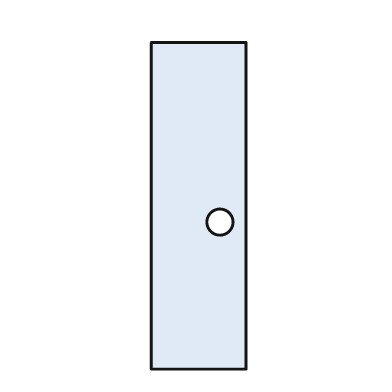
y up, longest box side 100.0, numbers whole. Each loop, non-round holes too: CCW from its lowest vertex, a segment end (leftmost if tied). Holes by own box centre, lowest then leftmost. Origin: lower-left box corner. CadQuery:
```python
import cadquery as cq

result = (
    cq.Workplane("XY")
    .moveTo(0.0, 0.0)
    .lineTo(29.0, 0.0)
    .lineTo(29.0, 100.0)
    .lineTo(0.0, 100.0)
    .close()
    .moveTo(21.0, 45.0)
    .circle(4.0)
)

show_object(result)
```